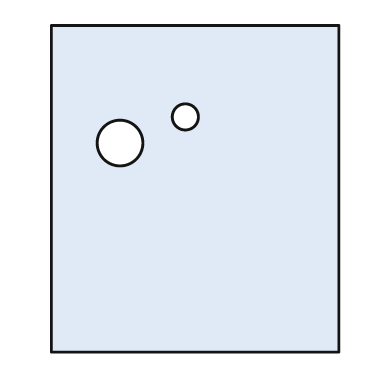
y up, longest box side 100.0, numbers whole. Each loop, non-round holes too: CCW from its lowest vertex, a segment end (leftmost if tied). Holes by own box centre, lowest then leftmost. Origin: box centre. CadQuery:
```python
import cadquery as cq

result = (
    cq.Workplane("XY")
    .moveTo(-44.0, -50.0)
    .lineTo(44.0, -50.0)
    .lineTo(44.0, 50.0)
    .lineTo(-44.0, 50.0)
    .close()
    .moveTo(-23.0, 14.0)
    .circle(7.0)
    .moveTo(-3.0, 22.0)
    .circle(4.0)
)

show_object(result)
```